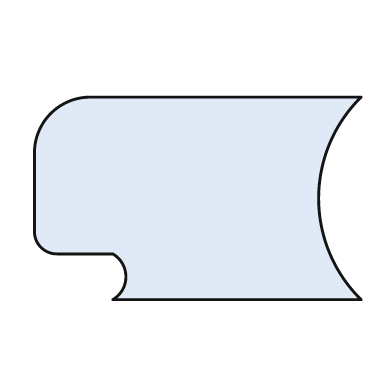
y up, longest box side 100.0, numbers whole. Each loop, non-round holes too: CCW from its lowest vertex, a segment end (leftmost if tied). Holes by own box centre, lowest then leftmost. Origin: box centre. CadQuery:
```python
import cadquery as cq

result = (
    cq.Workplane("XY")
    .moveTo(-26.0, -31.0)
    .lineTo(50.0, -31.0)
    .threePointArc((37.0, 0.0), (50.0, 31.0))
    .lineTo(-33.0, 31.0)
    .threePointArc((-45.0, 26.0), (-50.0, 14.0))
    .lineTo(-50.0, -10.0)
    .threePointArc((-48.0, -15.0), (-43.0, -17.0))
    .lineTo(-26.0, -17.0)
    .threePointArc((-22.0, -24.0), (-26.0, -31.0))
    .close()
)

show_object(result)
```